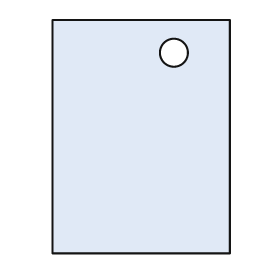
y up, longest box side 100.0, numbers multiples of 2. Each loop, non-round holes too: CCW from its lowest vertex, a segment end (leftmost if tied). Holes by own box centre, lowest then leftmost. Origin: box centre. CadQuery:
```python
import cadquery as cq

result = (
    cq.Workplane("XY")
    .moveTo(-38.0, -50.0)
    .lineTo(38.0, -50.0)
    .lineTo(38.0, 50.0)
    .lineTo(-38.0, 50.0)
    .close()
    .moveTo(14.0, 36.0)
    .circle(6.0)
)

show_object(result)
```